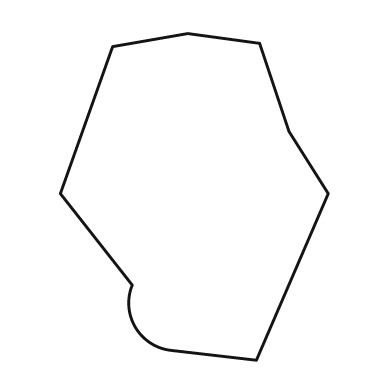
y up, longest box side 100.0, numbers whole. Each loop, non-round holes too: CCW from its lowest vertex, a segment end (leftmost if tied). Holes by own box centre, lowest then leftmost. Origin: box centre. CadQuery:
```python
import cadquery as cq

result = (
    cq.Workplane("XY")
    .moveTo(19.0, -50.0)
    .lineTo(41.0, 1.0)
    .lineTo(29.0, 20.0)
    .lineTo(20.0, 47.0)
    .lineTo(-2.0, 50.0)
    .lineTo(-25.0, 46.0)
    .lineTo(-41.0, 1.0)
    .lineTo(-19.0, -27.0)
    .threePointArc((-18.0, -40.0), (-7.0, -47.0))
    .close()
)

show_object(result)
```